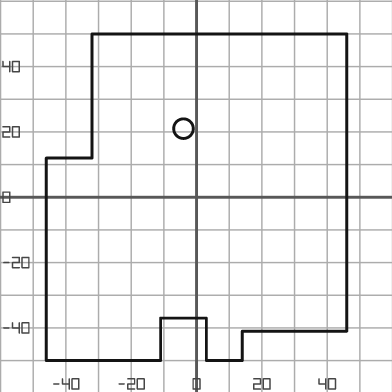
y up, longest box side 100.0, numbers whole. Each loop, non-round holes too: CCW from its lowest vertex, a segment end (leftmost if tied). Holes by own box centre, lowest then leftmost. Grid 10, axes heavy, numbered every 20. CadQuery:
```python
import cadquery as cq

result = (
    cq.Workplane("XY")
    .moveTo(-46.0, -50.0)
    .lineTo(-11.0, -50.0)
    .lineTo(-11.0, -37.0)
    .lineTo(3.0, -37.0)
    .lineTo(3.0, -50.0)
    .lineTo(14.0, -50.0)
    .lineTo(14.0, -41.0)
    .lineTo(46.0, -41.0)
    .lineTo(46.0, 50.0)
    .lineTo(-32.0, 50.0)
    .lineTo(-32.0, 12.0)
    .lineTo(-46.0, 12.0)
    .close()
    .moveTo(-4.0, 21.0)
    .circle(3.0)
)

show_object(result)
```